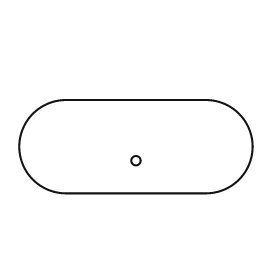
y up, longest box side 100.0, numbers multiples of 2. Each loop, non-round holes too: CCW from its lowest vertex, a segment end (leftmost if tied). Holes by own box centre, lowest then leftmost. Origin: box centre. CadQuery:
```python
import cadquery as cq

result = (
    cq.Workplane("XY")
    .moveTo(-30.0, -20.0)
    .lineTo(30.0, -20.0)
    .threePointArc((50.0, 0.0), (30.0, 20.0))
    .lineTo(-30.0, 20.0)
    .threePointArc((-50.0, 0.0), (-30.0, -20.0))
    .close()
    .moveTo(0.0, -6.0)
    .circle(2.0)
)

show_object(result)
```